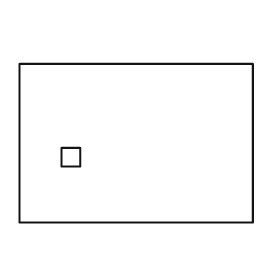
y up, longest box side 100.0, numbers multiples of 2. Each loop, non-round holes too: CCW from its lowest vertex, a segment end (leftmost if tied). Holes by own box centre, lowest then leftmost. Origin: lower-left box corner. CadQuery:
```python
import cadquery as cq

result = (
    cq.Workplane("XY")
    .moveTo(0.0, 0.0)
    .lineTo(100.0, 0.0)
    .lineTo(100.0, 68.0)
    .lineTo(0.0, 68.0)
    .close()
    .moveTo(18.0, 24.0)
    .lineTo(26.0, 24.0)
    .lineTo(26.0, 32.0)
    .lineTo(18.0, 32.0)
    .close()
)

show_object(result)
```